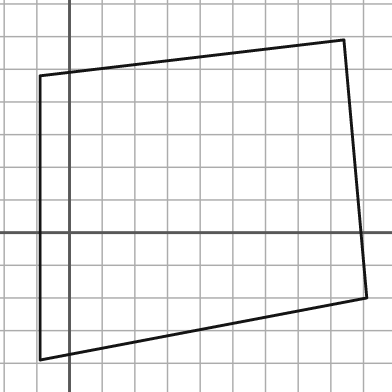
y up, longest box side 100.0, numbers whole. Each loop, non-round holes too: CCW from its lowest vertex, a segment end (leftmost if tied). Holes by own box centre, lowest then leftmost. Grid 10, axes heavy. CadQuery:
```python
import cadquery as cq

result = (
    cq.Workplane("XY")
    .moveTo(-9.0, -39.0)
    .lineTo(91.0, -20.0)
    .lineTo(84.0, 59.0)
    .lineTo(-9.0, 48.0)
    .close()
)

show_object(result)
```